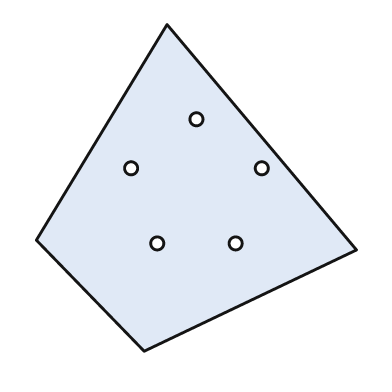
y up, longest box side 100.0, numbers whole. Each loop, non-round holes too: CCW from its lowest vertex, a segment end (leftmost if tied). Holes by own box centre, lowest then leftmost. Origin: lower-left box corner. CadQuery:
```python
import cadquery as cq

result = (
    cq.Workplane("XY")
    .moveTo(33.0, 0.0)
    .lineTo(98.0, 31.0)
    .lineTo(40.0, 100.0)
    .lineTo(0.0, 34.0)
    .close()
    .moveTo(37.0, 33.0)
    .circle(2.0)
    .moveTo(61.0, 33.0)
    .circle(2.0)
    .moveTo(29.0, 56.0)
    .circle(2.0)
    .moveTo(69.0, 56.0)
    .circle(2.0)
    .moveTo(49.0, 71.0)
    .circle(2.0)
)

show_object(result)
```